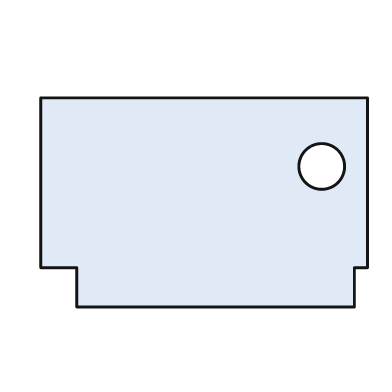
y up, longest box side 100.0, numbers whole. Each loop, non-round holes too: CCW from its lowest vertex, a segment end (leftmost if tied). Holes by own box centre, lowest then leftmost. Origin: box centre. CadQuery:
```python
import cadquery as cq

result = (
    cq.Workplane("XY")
    .moveTo(-39.0, -32.0)
    .lineTo(46.0, -32.0)
    .lineTo(46.0, -20.0)
    .lineTo(50.0, -20.0)
    .lineTo(50.0, 32.0)
    .lineTo(-50.0, 32.0)
    .lineTo(-50.0, -20.0)
    .lineTo(-39.0, -20.0)
    .close()
    .moveTo(36.0, 11.0)
    .circle(7.0)
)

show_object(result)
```